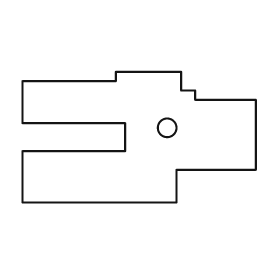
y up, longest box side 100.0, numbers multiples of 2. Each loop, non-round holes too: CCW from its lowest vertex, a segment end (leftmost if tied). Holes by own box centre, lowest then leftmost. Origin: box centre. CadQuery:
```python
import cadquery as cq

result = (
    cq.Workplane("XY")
    .moveTo(-50.0, -28.0)
    .lineTo(16.0, -28.0)
    .lineTo(16.0, -14.0)
    .lineTo(50.0, -14.0)
    .lineTo(50.0, 16.0)
    .lineTo(24.0, 16.0)
    .lineTo(24.0, 20.0)
    .lineTo(18.0, 20.0)
    .lineTo(18.0, 28.0)
    .lineTo(-10.0, 28.0)
    .lineTo(-10.0, 24.0)
    .lineTo(-50.0, 24.0)
    .lineTo(-50.0, 6.0)
    .lineTo(-6.0, 6.0)
    .lineTo(-6.0, -6.0)
    .lineTo(-50.0, -6.0)
    .close()
    .moveTo(12.0, 4.0)
    .circle(4.0)
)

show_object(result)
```